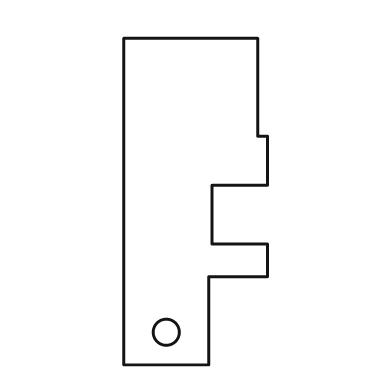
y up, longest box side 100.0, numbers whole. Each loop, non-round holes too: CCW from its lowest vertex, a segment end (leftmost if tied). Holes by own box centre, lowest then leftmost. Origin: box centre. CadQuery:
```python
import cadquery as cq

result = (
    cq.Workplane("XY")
    .moveTo(-22.0, -50.0)
    .lineTo(4.0, -50.0)
    .lineTo(4.0, -23.0)
    .lineTo(22.0, -23.0)
    .lineTo(22.0, -13.0)
    .lineTo(5.0, -13.0)
    .lineTo(5.0, 5.0)
    .lineTo(22.0, 5.0)
    .lineTo(22.0, 20.0)
    .lineTo(19.0, 20.0)
    .lineTo(19.0, 50.0)
    .lineTo(-22.0, 50.0)
    .close()
    .moveTo(-9.0, -40.0)
    .circle(4.0)
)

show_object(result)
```